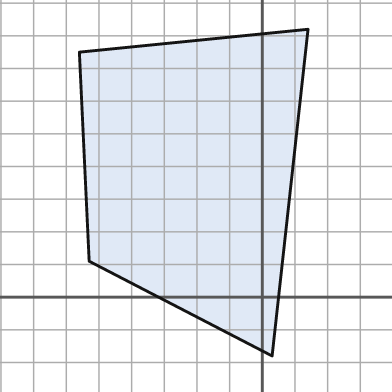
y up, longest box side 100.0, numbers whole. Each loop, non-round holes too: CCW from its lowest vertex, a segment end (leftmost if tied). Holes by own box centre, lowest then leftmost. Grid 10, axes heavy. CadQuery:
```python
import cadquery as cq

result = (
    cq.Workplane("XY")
    .moveTo(3.0, -18.0)
    .lineTo(14.0, 82.0)
    .lineTo(-56.0, 75.0)
    .lineTo(-53.0, 11.0)
    .close()
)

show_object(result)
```